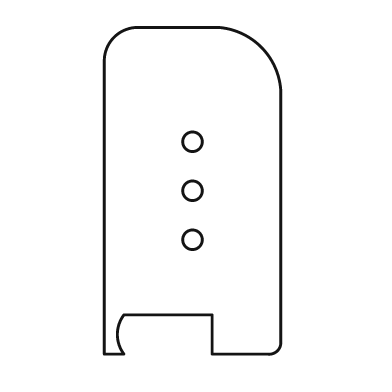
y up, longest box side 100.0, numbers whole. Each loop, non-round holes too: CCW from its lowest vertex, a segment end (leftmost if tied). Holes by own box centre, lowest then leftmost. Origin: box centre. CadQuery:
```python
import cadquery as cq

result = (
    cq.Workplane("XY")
    .moveTo(-27.0, -50.0)
    .lineTo(-21.0, -50.0)
    .threePointArc((-23.0, -44.0), (-21.0, -38.0))
    .lineTo(6.0, -38.0)
    .lineTo(6.0, -50.0)
    .lineTo(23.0, -50.0)
    .threePointArc((26.0, -49.0), (27.0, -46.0))
    .lineTo(27.0, 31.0)
    .threePointArc((21.0, 44.0), (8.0, 50.0))
    .lineTo(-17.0, 50.0)
    .threePointArc((-24.0, 47.0), (-27.0, 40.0))
    .close()
    .moveTo(0.0, -15.0)
    .circle(3.0)
    .moveTo(0.0, 0.0)
    .circle(3.0)
    .moveTo(0.0, 15.0)
    .circle(3.0)
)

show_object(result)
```